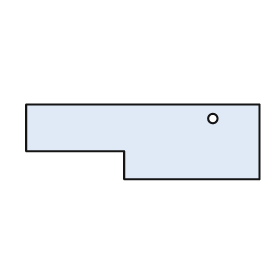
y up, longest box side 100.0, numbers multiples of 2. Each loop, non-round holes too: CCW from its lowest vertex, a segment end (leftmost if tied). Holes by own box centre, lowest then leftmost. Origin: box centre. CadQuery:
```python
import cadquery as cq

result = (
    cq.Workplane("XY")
    .moveTo(-8.0, -16.0)
    .lineTo(50.0, -16.0)
    .lineTo(50.0, 16.0)
    .lineTo(-50.0, 16.0)
    .lineTo(-50.0, -4.0)
    .lineTo(-8.0, -4.0)
    .close()
    .moveTo(30.0, 10.0)
    .circle(2.0)
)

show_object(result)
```